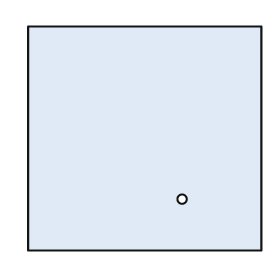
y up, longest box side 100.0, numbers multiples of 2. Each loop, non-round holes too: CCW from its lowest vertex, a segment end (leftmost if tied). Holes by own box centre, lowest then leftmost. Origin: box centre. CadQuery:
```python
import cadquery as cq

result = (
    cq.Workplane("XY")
    .moveTo(-50.0, -48.0)
    .lineTo(50.0, -48.0)
    .lineTo(50.0, 48.0)
    .lineTo(-50.0, 48.0)
    .close()
    .moveTo(16.0, -26.0)
    .circle(2.0)
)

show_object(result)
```